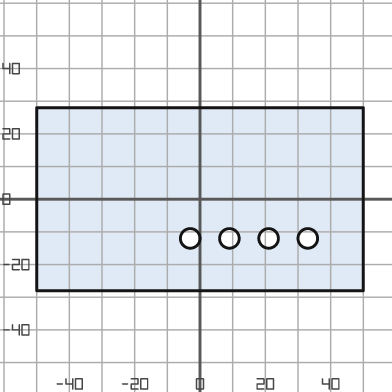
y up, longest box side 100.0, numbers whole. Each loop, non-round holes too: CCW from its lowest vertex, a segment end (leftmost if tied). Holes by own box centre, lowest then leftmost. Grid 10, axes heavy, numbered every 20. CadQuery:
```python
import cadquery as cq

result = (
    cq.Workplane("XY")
    .moveTo(-50.0, -28.0)
    .lineTo(50.0, -28.0)
    .lineTo(50.0, 28.0)
    .lineTo(-50.0, 28.0)
    .close()
    .moveTo(-3.0, -12.0)
    .circle(3.0)
    .moveTo(9.0, -12.0)
    .circle(3.0)
    .moveTo(21.0, -12.0)
    .circle(3.0)
    .moveTo(33.0, -12.0)
    .circle(3.0)
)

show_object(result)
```